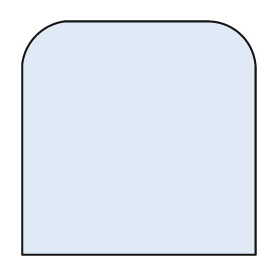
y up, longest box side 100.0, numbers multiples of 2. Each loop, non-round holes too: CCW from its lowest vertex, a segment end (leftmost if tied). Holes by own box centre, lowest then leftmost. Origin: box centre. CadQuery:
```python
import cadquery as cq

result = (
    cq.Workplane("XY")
    .moveTo(-50.0, -50.0)
    .lineTo(50.0, -50.0)
    .lineTo(50.0, 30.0)
    .threePointArc((44.0, 44.0), (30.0, 50.0))
    .lineTo(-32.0, 50.0)
    .threePointArc((-44.0, 44.0), (-50.0, 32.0))
    .close()
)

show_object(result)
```